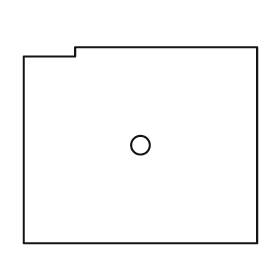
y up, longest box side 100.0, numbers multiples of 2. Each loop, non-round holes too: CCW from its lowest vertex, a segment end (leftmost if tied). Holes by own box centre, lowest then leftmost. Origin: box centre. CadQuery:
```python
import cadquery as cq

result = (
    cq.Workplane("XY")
    .moveTo(-50.0, -42.0)
    .lineTo(50.0, -42.0)
    .lineTo(50.0, 42.0)
    .lineTo(-28.0, 42.0)
    .lineTo(-28.0, 38.0)
    .lineTo(-50.0, 38.0)
    .close()
    .moveTo(0.0, 0.0)
    .circle(4.0)
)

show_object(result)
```